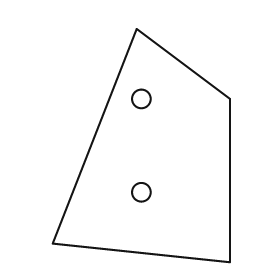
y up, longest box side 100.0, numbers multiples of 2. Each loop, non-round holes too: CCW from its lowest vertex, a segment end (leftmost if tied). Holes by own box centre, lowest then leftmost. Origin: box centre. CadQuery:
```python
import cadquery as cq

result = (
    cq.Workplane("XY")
    .moveTo(38.0, -50.0)
    .lineTo(38.0, 20.0)
    .lineTo(-2.0, 50.0)
    .lineTo(-38.0, -42.0)
    .close()
    .moveTo(0.0, -20.0)
    .circle(4.0)
    .moveTo(0.0, 20.0)
    .circle(4.0)
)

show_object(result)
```